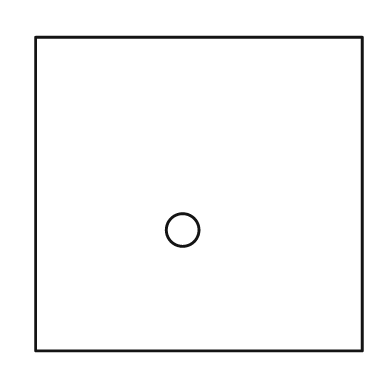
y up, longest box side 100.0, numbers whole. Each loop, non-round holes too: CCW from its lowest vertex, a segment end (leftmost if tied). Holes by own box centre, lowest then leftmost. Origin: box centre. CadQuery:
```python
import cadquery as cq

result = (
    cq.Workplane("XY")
    .moveTo(-50.0, -48.0)
    .lineTo(50.0, -48.0)
    .lineTo(50.0, 48.0)
    .lineTo(-50.0, 48.0)
    .close()
    .moveTo(-5.0, -11.0)
    .circle(5.0)
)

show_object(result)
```